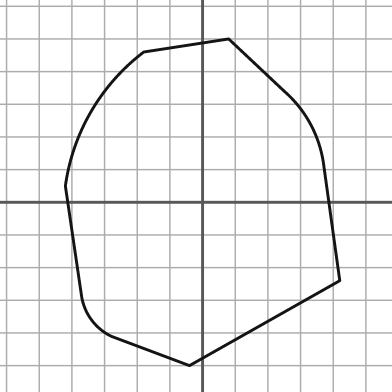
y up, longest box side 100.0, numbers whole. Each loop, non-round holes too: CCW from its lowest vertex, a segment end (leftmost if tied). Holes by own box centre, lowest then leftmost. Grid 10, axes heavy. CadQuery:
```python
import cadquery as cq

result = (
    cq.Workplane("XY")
    .moveTo(-4.0, -50.0)
    .lineTo(42.0, -24.0)
    .lineTo(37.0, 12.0)
    .threePointArc((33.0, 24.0), (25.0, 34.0))
    .lineTo(8.0, 50.0)
    .lineTo(-18.0, 46.0)
    .threePointArc((-34.0, 28.0), (-42.0, 5.0))
    .lineTo(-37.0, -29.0)
    .threePointArc((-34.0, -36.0), (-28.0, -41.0))
    .close()
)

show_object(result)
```